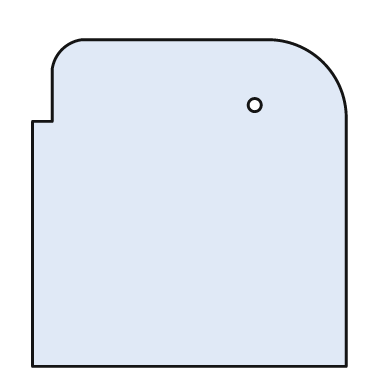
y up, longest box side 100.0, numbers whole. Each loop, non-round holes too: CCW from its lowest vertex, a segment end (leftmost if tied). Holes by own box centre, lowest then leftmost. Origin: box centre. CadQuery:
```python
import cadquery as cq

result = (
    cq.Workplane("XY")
    .moveTo(-48.0, -50.0)
    .lineTo(48.0, -50.0)
    .lineTo(48.0, 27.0)
    .threePointArc((41.0, 43.0), (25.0, 50.0))
    .lineTo(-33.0, 50.0)
    .threePointArc((-39.0, 47.0), (-42.0, 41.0))
    .lineTo(-42.0, 25.0)
    .lineTo(-48.0, 25.0)
    .close()
    .moveTo(20.0, 30.0)
    .circle(2.0)
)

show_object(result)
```